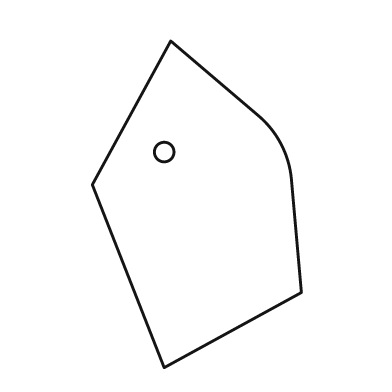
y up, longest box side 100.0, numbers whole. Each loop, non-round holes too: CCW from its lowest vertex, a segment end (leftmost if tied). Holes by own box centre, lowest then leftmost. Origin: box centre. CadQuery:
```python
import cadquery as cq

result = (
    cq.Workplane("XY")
    .moveTo(-10.0, -50.0)
    .lineTo(32.0, -27.0)
    .lineTo(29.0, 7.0)
    .threePointArc((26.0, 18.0), (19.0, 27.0))
    .lineTo(-8.0, 50.0)
    .lineTo(-32.0, 6.0)
    .close()
    .moveTo(-10.0, 16.0)
    .circle(3.0)
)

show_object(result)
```